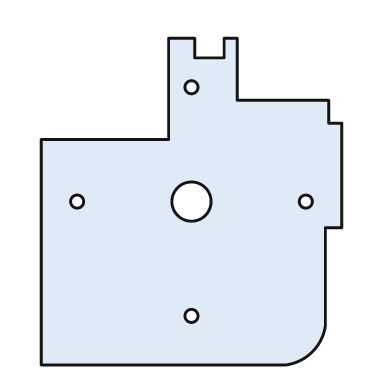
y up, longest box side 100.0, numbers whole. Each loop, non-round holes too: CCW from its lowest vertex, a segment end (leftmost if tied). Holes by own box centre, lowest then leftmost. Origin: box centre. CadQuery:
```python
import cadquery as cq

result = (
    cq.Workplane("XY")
    .moveTo(-46.0, -50.0)
    .lineTo(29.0, -50.0)
    .threePointArc((37.0, -46.0), (41.0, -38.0))
    .lineTo(41.0, -8.0)
    .lineTo(46.0, -8.0)
    .lineTo(46.0, 24.0)
    .lineTo(42.0, 24.0)
    .lineTo(42.0, 31.0)
    .lineTo(14.0, 31.0)
    .lineTo(14.0, 50.0)
    .lineTo(10.0, 50.0)
    .lineTo(10.0, 44.0)
    .lineTo(1.0, 44.0)
    .lineTo(1.0, 50.0)
    .lineTo(-7.0, 50.0)
    .lineTo(-7.0, 19.0)
    .lineTo(-46.0, 19.0)
    .close()
    .moveTo(0.0, -35.0)
    .circle(2.0)
    .moveTo(-35.0, 0.0)
    .circle(2.0)
    .moveTo(0.0, 0.0)
    .circle(6.0)
    .moveTo(35.0, 0.0)
    .circle(2.0)
    .moveTo(0.0, 35.0)
    .circle(2.0)
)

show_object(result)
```